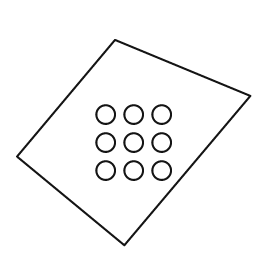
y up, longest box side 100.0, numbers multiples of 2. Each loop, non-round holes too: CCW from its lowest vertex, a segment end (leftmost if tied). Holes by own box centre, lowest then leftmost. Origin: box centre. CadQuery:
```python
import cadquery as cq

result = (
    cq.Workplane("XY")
    .moveTo(-4.0, -44.0)
    .lineTo(50.0, 20.0)
    .lineTo(-8.0, 44.0)
    .lineTo(-50.0, -6.0)
    .close()
    .moveTo(-12.0, -12.0)
    .circle(4.0)
    .moveTo(0.0, -12.0)
    .circle(4.0)
    .moveTo(12.0, -12.0)
    .circle(4.0)
    .moveTo(-12.0, 0.0)
    .circle(4.0)
    .moveTo(0.0, 0.0)
    .circle(4.0)
    .moveTo(12.0, 0.0)
    .circle(4.0)
    .moveTo(-12.0, 12.0)
    .circle(4.0)
    .moveTo(0.0, 12.0)
    .circle(4.0)
    .moveTo(12.0, 12.0)
    .circle(4.0)
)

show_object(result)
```